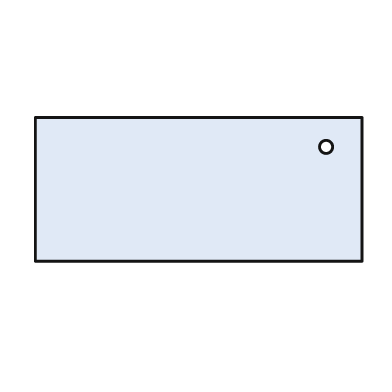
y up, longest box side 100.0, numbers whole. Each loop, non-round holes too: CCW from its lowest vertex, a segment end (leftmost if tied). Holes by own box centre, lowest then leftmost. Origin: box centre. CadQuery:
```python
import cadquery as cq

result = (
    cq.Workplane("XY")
    .moveTo(-50.0, -22.0)
    .lineTo(50.0, -22.0)
    .lineTo(50.0, 22.0)
    .lineTo(-50.0, 22.0)
    .close()
    .moveTo(39.0, 13.0)
    .circle(2.0)
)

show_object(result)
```